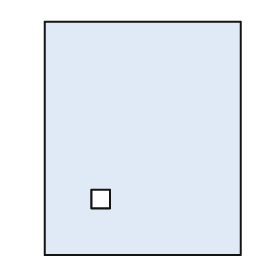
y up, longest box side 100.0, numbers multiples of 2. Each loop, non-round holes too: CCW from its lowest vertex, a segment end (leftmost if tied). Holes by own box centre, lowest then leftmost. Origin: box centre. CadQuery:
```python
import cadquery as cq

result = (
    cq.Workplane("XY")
    .moveTo(-42.0, -50.0)
    .lineTo(42.0, -50.0)
    .lineTo(42.0, 50.0)
    .lineTo(-42.0, 50.0)
    .close()
    .moveTo(-22.0, -30.0)
    .lineTo(-14.0, -30.0)
    .lineTo(-14.0, -22.0)
    .lineTo(-22.0, -22.0)
    .close()
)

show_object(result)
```